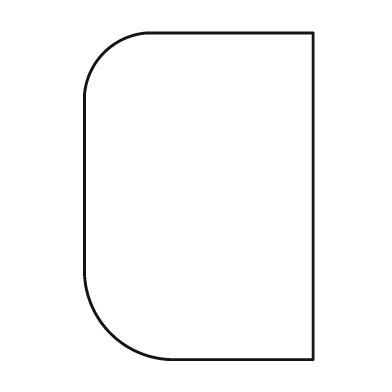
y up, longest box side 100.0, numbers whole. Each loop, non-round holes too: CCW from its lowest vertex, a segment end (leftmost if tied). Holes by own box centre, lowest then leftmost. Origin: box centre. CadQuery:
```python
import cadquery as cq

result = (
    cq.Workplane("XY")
    .moveTo(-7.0, -50.0)
    .lineTo(35.0, -50.0)
    .lineTo(35.0, 50.0)
    .lineTo(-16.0, 50.0)
    .threePointArc((-29.0, 44.0), (-35.0, 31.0))
    .lineTo(-35.0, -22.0)
    .threePointArc((-27.0, -42.0), (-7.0, -50.0))
    .close()
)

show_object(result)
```